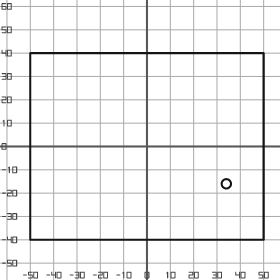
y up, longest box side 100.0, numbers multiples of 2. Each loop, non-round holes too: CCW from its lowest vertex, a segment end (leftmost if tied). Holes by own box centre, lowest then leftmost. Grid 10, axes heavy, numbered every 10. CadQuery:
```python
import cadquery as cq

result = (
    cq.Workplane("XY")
    .moveTo(-50.0, -40.0)
    .lineTo(50.0, -40.0)
    .lineTo(50.0, 40.0)
    .lineTo(-50.0, 40.0)
    .close()
    .moveTo(34.0, -16.0)
    .circle(2.0)
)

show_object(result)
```